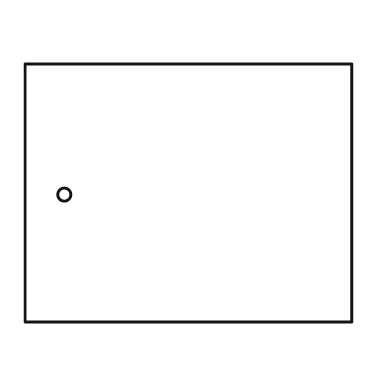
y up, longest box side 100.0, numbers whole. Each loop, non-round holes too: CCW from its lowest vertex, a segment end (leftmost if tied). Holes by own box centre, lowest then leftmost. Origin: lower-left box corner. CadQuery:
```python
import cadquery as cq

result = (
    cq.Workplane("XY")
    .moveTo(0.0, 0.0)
    .lineTo(100.0, 0.0)
    .lineTo(100.0, 79.0)
    .lineTo(0.0, 79.0)
    .close()
    .moveTo(12.0, 39.0)
    .circle(2.0)
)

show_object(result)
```